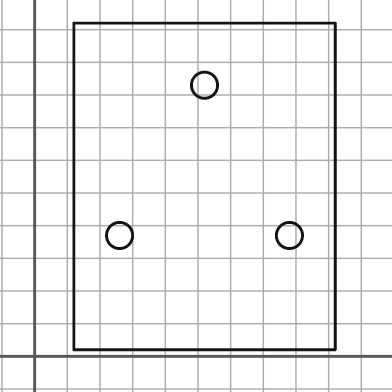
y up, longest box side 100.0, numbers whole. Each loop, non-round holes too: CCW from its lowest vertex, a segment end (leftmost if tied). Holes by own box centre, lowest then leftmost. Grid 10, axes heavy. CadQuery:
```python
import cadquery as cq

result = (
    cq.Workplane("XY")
    .moveTo(12.0, 2.0)
    .lineTo(92.0, 2.0)
    .lineTo(92.0, 102.0)
    .lineTo(12.0, 102.0)
    .close()
    .moveTo(26.0, 37.0)
    .circle(4.0)
    .moveTo(78.0, 37.0)
    .circle(4.0)
    .moveTo(52.0, 83.0)
    .circle(4.0)
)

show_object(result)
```